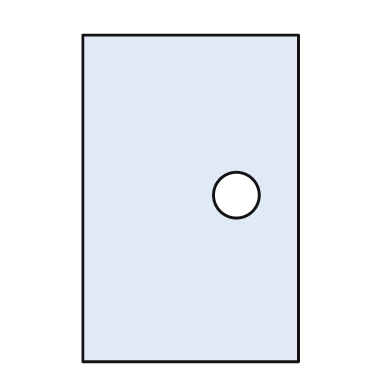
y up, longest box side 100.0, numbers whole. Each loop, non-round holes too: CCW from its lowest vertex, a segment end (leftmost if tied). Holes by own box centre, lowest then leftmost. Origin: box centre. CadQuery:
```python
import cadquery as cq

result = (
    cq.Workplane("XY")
    .moveTo(-33.0, -50.0)
    .lineTo(33.0, -50.0)
    .lineTo(33.0, 50.0)
    .lineTo(-33.0, 50.0)
    .close()
    .moveTo(14.0, 1.0)
    .circle(7.0)
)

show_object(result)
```